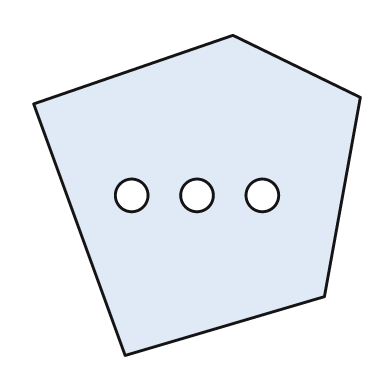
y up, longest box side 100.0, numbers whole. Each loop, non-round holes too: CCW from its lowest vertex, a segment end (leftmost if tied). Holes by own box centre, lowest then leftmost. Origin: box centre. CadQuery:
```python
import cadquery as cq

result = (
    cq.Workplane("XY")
    .moveTo(-22.0, -49.0)
    .lineTo(39.0, -31.0)
    .lineTo(50.0, 30.0)
    .lineTo(11.0, 49.0)
    .lineTo(-50.0, 28.0)
    .close()
    .moveTo(-20.0, 0.0)
    .circle(5.0)
    .moveTo(0.0, 0.0)
    .circle(5.0)
    .moveTo(20.0, 0.0)
    .circle(5.0)
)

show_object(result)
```